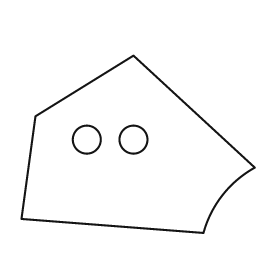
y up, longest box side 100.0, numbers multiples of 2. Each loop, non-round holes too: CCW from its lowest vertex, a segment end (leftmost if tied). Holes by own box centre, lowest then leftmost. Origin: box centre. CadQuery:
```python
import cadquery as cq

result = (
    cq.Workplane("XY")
    .moveTo(28.0, -38.0)
    .threePointArc((36.0, -22.0), (50.0, -10.0))
    .lineTo(-2.0, 38.0)
    .lineTo(-44.0, 12.0)
    .lineTo(-50.0, -32.0)
    .close()
    .moveTo(-22.0, 2.0)
    .circle(6.0)
    .moveTo(-2.0, 2.0)
    .circle(6.0)
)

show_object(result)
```